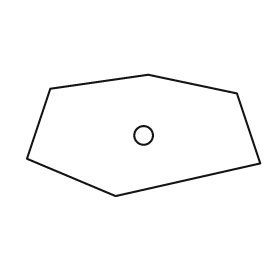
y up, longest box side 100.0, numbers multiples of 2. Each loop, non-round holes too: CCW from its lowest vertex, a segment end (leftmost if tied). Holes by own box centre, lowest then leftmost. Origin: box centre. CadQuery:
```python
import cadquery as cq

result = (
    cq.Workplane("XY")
    .moveTo(-12.0, -26.0)
    .lineTo(50.0, -12.0)
    .lineTo(40.0, 18.0)
    .lineTo(2.0, 26.0)
    .lineTo(-40.0, 20.0)
    .lineTo(-50.0, -10.0)
    .close()
    .moveTo(0.0, 0.0)
    .circle(4.0)
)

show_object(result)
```